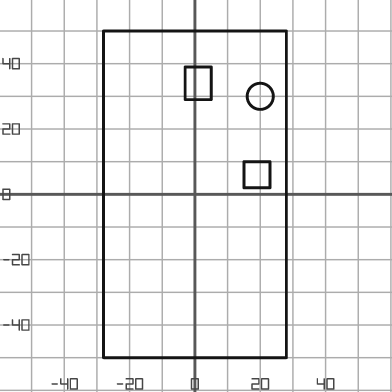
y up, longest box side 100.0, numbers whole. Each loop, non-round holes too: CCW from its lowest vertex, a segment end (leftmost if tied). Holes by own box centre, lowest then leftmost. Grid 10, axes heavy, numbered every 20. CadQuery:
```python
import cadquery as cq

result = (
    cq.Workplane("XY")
    .moveTo(-28.0, -50.0)
    .lineTo(28.0, -50.0)
    .lineTo(28.0, 50.0)
    .lineTo(-28.0, 50.0)
    .close()
    .moveTo(15.0, 2.0)
    .lineTo(23.0, 2.0)
    .lineTo(23.0, 10.0)
    .lineTo(15.0, 10.0)
    .close()
    .moveTo(20.0, 30.0)
    .circle(4.0)
    .moveTo(-3.0, 29.0)
    .lineTo(5.0, 29.0)
    .lineTo(5.0, 39.0)
    .lineTo(-3.0, 39.0)
    .close()
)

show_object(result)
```